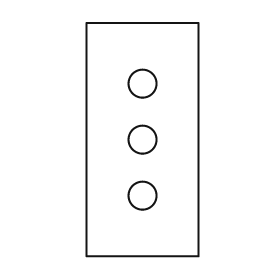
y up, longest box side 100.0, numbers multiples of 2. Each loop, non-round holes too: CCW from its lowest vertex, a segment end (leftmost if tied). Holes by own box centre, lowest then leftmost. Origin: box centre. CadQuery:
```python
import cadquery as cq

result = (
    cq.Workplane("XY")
    .moveTo(-24.0, -50.0)
    .lineTo(24.0, -50.0)
    .lineTo(24.0, 50.0)
    .lineTo(-24.0, 50.0)
    .close()
    .moveTo(0.0, -24.0)
    .circle(6.0)
    .moveTo(0.0, 0.0)
    .circle(6.0)
    .moveTo(0.0, 24.0)
    .circle(6.0)
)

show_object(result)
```